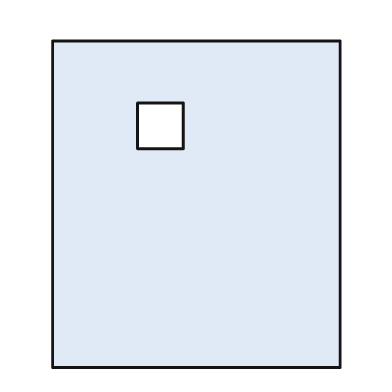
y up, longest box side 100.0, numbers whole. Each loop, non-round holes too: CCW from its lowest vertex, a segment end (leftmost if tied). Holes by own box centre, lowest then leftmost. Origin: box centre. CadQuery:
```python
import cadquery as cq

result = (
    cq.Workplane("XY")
    .moveTo(-44.0, -50.0)
    .lineTo(44.0, -50.0)
    .lineTo(44.0, 50.0)
    .lineTo(-44.0, 50.0)
    .close()
    .moveTo(-18.0, 17.0)
    .lineTo(-4.0, 17.0)
    .lineTo(-4.0, 31.0)
    .lineTo(-18.0, 31.0)
    .close()
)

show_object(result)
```